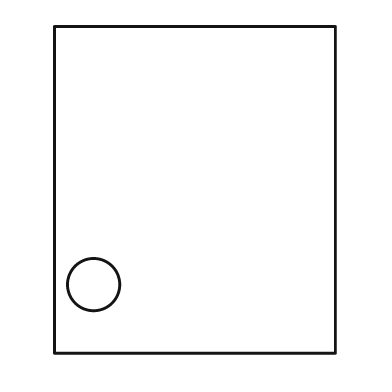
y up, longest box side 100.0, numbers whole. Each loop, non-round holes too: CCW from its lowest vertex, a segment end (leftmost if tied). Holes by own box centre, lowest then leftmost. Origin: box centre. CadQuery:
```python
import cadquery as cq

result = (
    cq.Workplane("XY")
    .moveTo(-43.0, -50.0)
    .lineTo(43.0, -50.0)
    .lineTo(43.0, 50.0)
    .lineTo(-43.0, 50.0)
    .close()
    .moveTo(-31.0, -29.0)
    .circle(8.0)
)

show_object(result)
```